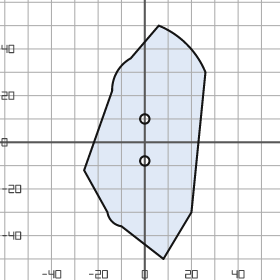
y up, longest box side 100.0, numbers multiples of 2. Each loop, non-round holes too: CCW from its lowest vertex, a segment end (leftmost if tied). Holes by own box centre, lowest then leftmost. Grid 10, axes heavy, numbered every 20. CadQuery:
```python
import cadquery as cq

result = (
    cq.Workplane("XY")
    .moveTo(8.0, -50.0)
    .lineTo(20.0, -30.0)
    .lineTo(26.0, 30.0)
    .threePointArc((18.0, 42.0), (6.0, 50.0))
    .lineTo(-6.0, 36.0)
    .threePointArc((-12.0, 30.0), (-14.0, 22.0))
    .lineTo(-26.0, -12.0)
    .lineTo(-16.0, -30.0)
    .threePointArc((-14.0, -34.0), (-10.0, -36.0))
    .close()
    .moveTo(0.0, -8.0)
    .circle(2.0)
    .moveTo(0.0, 10.0)
    .circle(2.0)
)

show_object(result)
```